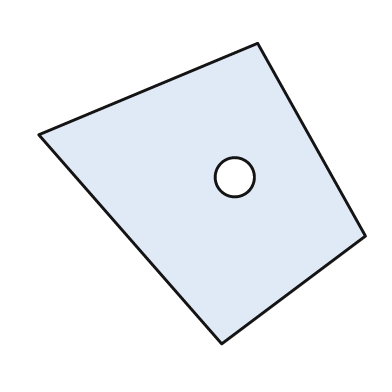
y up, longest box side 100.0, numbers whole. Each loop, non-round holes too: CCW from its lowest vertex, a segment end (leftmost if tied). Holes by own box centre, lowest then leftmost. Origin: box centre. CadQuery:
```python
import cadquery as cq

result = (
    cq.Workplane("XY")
    .moveTo(6.0, -46.0)
    .lineTo(50.0, -13.0)
    .lineTo(17.0, 46.0)
    .lineTo(-50.0, 18.0)
    .close()
    .moveTo(10.0, 5.0)
    .circle(6.0)
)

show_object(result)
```